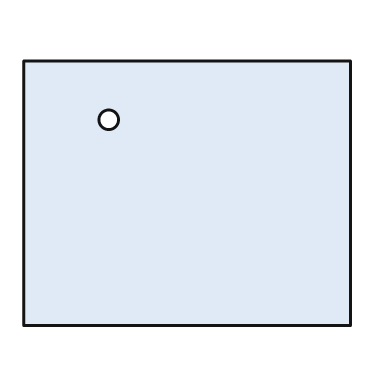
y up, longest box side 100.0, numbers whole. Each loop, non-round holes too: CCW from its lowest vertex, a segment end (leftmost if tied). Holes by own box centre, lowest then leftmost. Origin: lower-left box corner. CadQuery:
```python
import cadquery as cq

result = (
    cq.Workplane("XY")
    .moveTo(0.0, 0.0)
    .lineTo(100.0, 0.0)
    .lineTo(100.0, 81.0)
    .lineTo(0.0, 81.0)
    .close()
    .moveTo(26.0, 63.0)
    .circle(3.0)
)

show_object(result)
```